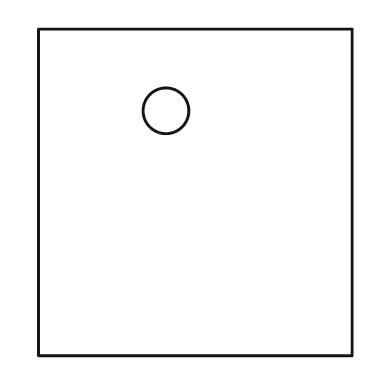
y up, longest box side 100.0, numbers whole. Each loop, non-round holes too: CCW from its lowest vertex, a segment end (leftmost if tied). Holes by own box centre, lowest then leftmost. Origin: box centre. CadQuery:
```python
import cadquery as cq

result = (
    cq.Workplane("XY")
    .moveTo(-48.0, -50.0)
    .lineTo(48.0, -50.0)
    .lineTo(48.0, 50.0)
    .lineTo(-48.0, 50.0)
    .close()
    .moveTo(-9.0, 25.0)
    .circle(7.0)
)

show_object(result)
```